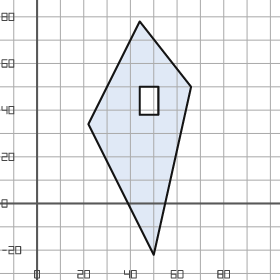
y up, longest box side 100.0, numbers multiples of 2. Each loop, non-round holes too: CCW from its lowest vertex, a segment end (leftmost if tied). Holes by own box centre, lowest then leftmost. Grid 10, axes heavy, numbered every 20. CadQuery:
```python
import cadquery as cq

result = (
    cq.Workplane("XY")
    .moveTo(50.0, -22.0)
    .lineTo(66.0, 50.0)
    .lineTo(44.0, 78.0)
    .lineTo(22.0, 34.0)
    .close()
    .moveTo(44.0, 38.0)
    .lineTo(52.0, 38.0)
    .lineTo(52.0, 50.0)
    .lineTo(44.0, 50.0)
    .close()
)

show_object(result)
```